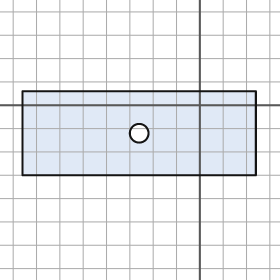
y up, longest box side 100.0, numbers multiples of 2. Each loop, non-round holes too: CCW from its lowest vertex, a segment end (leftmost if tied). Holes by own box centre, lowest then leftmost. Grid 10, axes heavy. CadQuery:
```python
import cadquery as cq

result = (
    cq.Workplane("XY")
    .moveTo(-76.0, -30.0)
    .lineTo(24.0, -30.0)
    .lineTo(24.0, 6.0)
    .lineTo(-76.0, 6.0)
    .close()
    .moveTo(-26.0, -12.0)
    .circle(4.0)
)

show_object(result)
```